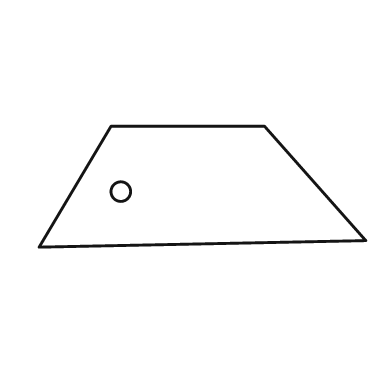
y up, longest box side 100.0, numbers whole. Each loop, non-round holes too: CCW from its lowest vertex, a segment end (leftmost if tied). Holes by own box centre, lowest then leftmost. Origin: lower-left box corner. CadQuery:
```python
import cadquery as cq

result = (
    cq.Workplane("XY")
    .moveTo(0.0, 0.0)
    .lineTo(100.0, 2.0)
    .lineTo(69.0, 37.0)
    .lineTo(22.0, 37.0)
    .close()
    .moveTo(25.0, 17.0)
    .circle(3.0)
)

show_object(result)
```